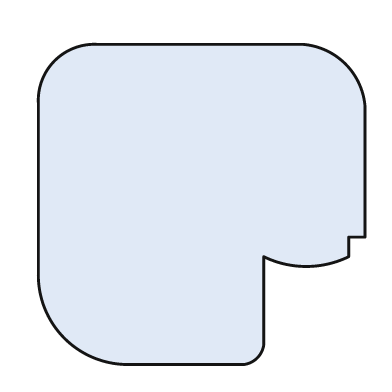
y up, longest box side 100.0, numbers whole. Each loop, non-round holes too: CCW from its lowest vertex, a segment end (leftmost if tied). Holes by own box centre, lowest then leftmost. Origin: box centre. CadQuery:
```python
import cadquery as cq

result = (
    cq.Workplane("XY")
    .moveTo(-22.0, -49.0)
    .lineTo(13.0, -49.0)
    .threePointArc((17.0, -47.0), (19.0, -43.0))
    .lineTo(19.0, -16.0)
    .threePointArc((32.0, -19.0), (45.0, -16.0))
    .lineTo(45.0, -10.0)
    .lineTo(50.0, -10.0)
    .lineTo(50.0, 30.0)
    .threePointArc((44.0, 43.0), (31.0, 49.0))
    .lineTo(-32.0, 49.0)
    .threePointArc((-45.0, 44.0), (-50.0, 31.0))
    .lineTo(-50.0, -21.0)
    .threePointArc((-42.0, -41.0), (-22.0, -49.0))
    .close()
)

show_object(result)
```